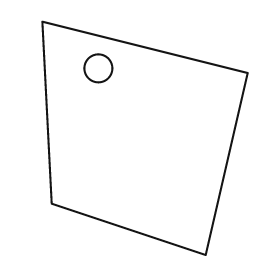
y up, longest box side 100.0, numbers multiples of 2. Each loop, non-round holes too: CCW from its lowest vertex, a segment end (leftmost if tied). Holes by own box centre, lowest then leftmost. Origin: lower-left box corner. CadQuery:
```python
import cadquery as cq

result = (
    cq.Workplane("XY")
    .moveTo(70.0, 0.0)
    .lineTo(88.0, 78.0)
    .lineTo(0.0, 100.0)
    .lineTo(4.0, 22.0)
    .close()
    .moveTo(24.0, 80.0)
    .circle(6.0)
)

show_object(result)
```